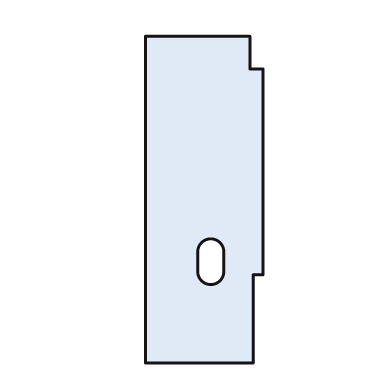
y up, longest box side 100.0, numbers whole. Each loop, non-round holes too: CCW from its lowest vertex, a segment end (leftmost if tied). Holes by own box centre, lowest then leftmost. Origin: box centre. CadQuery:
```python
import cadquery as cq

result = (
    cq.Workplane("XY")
    .moveTo(-18.0, -50.0)
    .lineTo(15.0, -50.0)
    .lineTo(15.0, -23.0)
    .lineTo(18.0, -23.0)
    .lineTo(18.0, 40.0)
    .lineTo(14.0, 40.0)
    .lineTo(14.0, 50.0)
    .lineTo(-18.0, 50.0)
    .close()
    .moveTo(-2.0, -22.0)
    .threePointArc((2.0, -26.0), (6.0, -22.0))
    .lineTo(6.0, -16.0)
    .threePointArc((2.0, -12.0), (-2.0, -16.0))
    .close()
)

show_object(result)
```